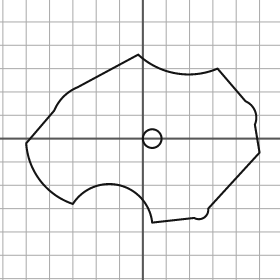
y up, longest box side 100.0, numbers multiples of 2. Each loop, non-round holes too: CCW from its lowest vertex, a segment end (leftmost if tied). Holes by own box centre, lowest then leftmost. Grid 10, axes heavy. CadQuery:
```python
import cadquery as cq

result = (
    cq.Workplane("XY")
    .moveTo(4.0, -36.0)
    .lineTo(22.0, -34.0)
    .threePointArc((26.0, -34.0), (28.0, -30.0))
    .lineTo(50.0, -6.0)
    .lineTo(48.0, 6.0)
    .threePointArc((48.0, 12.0), (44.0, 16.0))
    .lineTo(32.0, 30.0)
    .threePointArc((14.0, 28.0), (-2.0, 36.0))
    .lineTo(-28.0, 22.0)
    .threePointArc((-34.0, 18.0), (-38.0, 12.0))
    .lineTo(-50.0, -2.0)
    .threePointArc((-44.0, -18.0), (-30.0, -28.0))
    .threePointArc((-10.0, -20.0), (4.0, -36.0))
    .close()
    .moveTo(4.0, 0.0)
    .circle(4.0)
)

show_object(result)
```